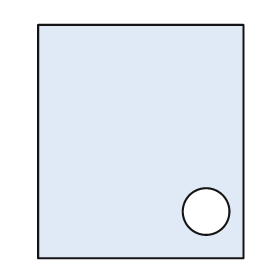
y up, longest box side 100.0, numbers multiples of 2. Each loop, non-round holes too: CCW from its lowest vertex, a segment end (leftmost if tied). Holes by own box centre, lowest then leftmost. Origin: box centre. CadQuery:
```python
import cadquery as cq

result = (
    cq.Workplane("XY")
    .moveTo(-44.0, -50.0)
    .lineTo(44.0, -50.0)
    .lineTo(44.0, 50.0)
    .lineTo(-44.0, 50.0)
    .close()
    .moveTo(28.0, -30.0)
    .circle(10.0)
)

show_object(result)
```